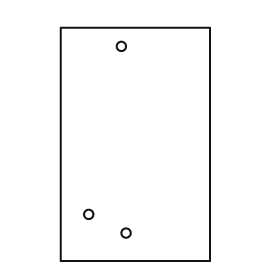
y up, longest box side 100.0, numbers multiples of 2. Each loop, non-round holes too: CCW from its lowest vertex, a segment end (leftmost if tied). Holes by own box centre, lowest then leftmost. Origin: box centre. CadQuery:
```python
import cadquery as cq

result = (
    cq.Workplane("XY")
    .moveTo(-32.0, -50.0)
    .lineTo(32.0, -50.0)
    .lineTo(32.0, 50.0)
    .lineTo(-32.0, 50.0)
    .close()
    .moveTo(-4.0, -38.0)
    .circle(2.0)
    .moveTo(-20.0, -30.0)
    .circle(2.0)
    .moveTo(-6.0, 42.0)
    .circle(2.0)
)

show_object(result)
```